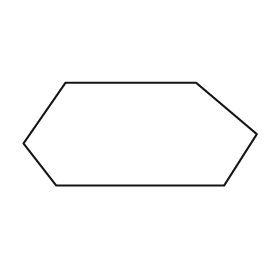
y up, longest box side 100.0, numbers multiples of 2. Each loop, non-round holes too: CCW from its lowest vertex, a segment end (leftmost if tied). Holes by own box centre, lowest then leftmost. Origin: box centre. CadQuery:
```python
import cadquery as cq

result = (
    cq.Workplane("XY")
    .moveTo(-36.0, -22.0)
    .lineTo(36.0, -22.0)
    .lineTo(50.0, 0.0)
    .lineTo(24.0, 22.0)
    .lineTo(-32.0, 22.0)
    .lineTo(-50.0, -4.0)
    .close()
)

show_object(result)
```